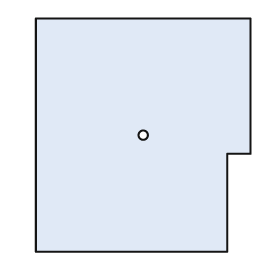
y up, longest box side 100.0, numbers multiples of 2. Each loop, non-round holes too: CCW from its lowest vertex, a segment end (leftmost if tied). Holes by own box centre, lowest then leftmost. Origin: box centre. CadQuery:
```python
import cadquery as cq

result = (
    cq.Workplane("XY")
    .moveTo(-46.0, -50.0)
    .lineTo(36.0, -50.0)
    .lineTo(36.0, -8.0)
    .lineTo(46.0, -8.0)
    .lineTo(46.0, 50.0)
    .lineTo(-46.0, 50.0)
    .close()
    .moveTo(0.0, 0.0)
    .circle(2.0)
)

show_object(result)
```